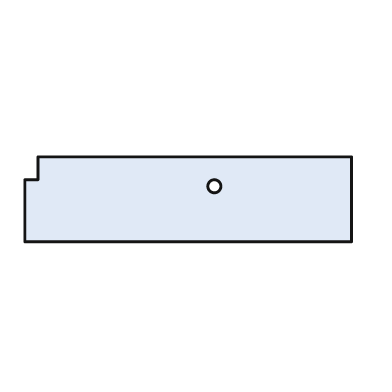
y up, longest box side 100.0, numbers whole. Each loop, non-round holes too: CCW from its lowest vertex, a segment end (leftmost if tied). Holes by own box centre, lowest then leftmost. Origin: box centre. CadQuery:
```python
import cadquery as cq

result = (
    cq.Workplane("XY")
    .moveTo(-50.0, -13.0)
    .lineTo(50.0, -13.0)
    .lineTo(50.0, 13.0)
    .lineTo(-46.0, 13.0)
    .lineTo(-46.0, 6.0)
    .lineTo(-50.0, 6.0)
    .close()
    .moveTo(8.0, 4.0)
    .circle(2.0)
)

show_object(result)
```